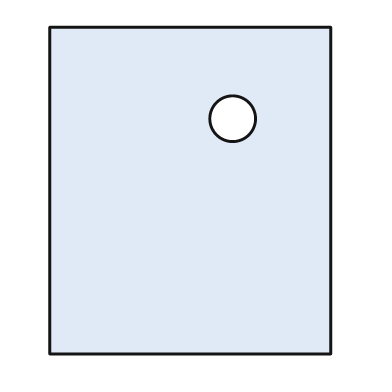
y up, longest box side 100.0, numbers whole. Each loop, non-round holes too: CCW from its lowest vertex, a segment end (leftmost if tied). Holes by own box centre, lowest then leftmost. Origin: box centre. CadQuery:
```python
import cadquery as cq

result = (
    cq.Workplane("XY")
    .moveTo(-43.0, -50.0)
    .lineTo(43.0, -50.0)
    .lineTo(43.0, 50.0)
    .lineTo(-43.0, 50.0)
    .close()
    .moveTo(13.0, 22.0)
    .circle(7.0)
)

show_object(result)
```